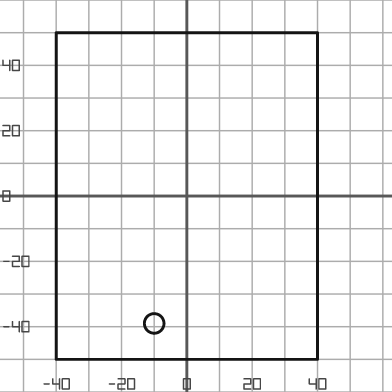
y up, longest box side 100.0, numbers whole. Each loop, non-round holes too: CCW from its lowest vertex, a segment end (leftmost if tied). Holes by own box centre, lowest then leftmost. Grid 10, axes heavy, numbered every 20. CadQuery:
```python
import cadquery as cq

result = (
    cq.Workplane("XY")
    .moveTo(-40.0, -50.0)
    .lineTo(40.0, -50.0)
    .lineTo(40.0, 50.0)
    .lineTo(-40.0, 50.0)
    .close()
    .moveTo(-10.0, -39.0)
    .circle(3.0)
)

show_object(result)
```